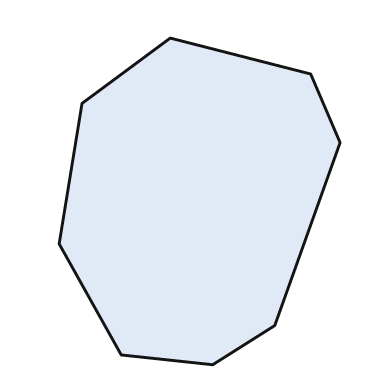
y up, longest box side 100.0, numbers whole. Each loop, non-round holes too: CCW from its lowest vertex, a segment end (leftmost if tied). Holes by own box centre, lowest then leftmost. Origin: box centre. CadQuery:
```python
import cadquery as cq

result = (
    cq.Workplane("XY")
    .moveTo(4.0, -50.0)
    .lineTo(23.0, -38.0)
    .lineTo(43.0, 18.0)
    .lineTo(34.0, 39.0)
    .lineTo(-9.0, 50.0)
    .lineTo(-36.0, 30.0)
    .lineTo(-43.0, -13.0)
    .lineTo(-24.0, -47.0)
    .close()
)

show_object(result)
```